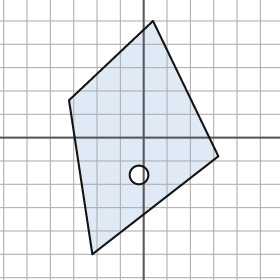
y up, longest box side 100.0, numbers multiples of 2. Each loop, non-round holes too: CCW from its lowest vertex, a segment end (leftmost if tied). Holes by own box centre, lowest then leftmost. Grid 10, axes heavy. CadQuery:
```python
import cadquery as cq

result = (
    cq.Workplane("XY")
    .moveTo(-22.0, -50.0)
    .lineTo(32.0, -8.0)
    .lineTo(4.0, 50.0)
    .lineTo(-32.0, 16.0)
    .close()
    .moveTo(-2.0, -16.0)
    .circle(4.0)
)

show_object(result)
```